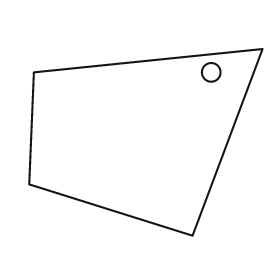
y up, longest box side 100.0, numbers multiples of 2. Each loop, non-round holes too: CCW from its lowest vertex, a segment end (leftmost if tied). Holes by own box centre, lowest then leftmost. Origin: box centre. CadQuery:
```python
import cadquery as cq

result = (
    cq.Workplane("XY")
    .moveTo(20.0, -40.0)
    .lineTo(50.0, 40.0)
    .lineTo(-48.0, 30.0)
    .lineTo(-50.0, -18.0)
    .close()
    .moveTo(28.0, 30.0)
    .circle(4.0)
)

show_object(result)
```